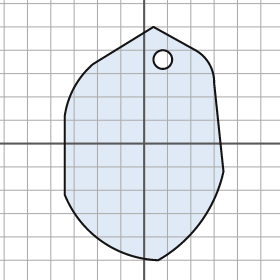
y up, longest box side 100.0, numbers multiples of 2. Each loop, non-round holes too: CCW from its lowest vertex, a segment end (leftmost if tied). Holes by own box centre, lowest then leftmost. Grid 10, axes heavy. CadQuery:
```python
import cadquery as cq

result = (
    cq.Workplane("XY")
    .moveTo(6.0, -50.0)
    .threePointArc((24.0, -34.0), (34.0, -12.0))
    .lineTo(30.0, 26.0)
    .threePointArc((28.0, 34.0), (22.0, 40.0))
    .lineTo(4.0, 50.0)
    .lineTo(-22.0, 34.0)
    .threePointArc((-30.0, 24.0), (-34.0, 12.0))
    .lineTo(-34.0, -22.0)
    .threePointArc((-18.0, -42.0), (6.0, -50.0))
    .close()
    .moveTo(8.0, 36.0)
    .circle(4.0)
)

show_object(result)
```